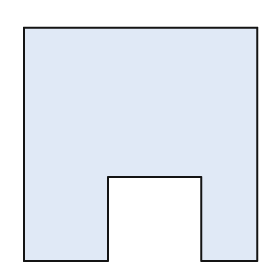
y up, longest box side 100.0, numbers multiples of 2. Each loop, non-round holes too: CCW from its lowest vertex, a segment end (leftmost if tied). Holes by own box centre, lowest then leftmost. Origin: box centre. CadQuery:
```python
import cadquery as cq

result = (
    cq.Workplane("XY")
    .moveTo(-50.0, -50.0)
    .lineTo(-14.0, -50.0)
    .lineTo(-14.0, -14.0)
    .lineTo(26.0, -14.0)
    .lineTo(26.0, -50.0)
    .lineTo(50.0, -50.0)
    .lineTo(50.0, 50.0)
    .lineTo(-50.0, 50.0)
    .close()
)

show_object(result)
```